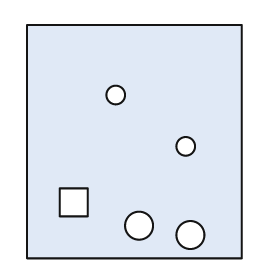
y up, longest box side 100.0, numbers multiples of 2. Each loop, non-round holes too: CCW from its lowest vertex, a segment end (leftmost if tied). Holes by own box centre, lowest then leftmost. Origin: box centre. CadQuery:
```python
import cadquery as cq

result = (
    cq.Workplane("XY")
    .moveTo(-46.0, -50.0)
    .lineTo(46.0, -50.0)
    .lineTo(46.0, 50.0)
    .lineTo(-46.0, 50.0)
    .close()
    .moveTo(24.0, -40.0)
    .circle(6.0)
    .moveTo(2.0, -36.0)
    .circle(6.0)
    .moveTo(-32.0, -32.0)
    .lineTo(-20.0, -32.0)
    .lineTo(-20.0, -20.0)
    .lineTo(-32.0, -20.0)
    .close()
    .moveTo(22.0, -2.0)
    .circle(4.0)
    .moveTo(-8.0, 20.0)
    .circle(4.0)
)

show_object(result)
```